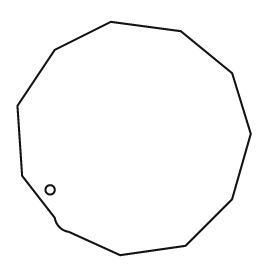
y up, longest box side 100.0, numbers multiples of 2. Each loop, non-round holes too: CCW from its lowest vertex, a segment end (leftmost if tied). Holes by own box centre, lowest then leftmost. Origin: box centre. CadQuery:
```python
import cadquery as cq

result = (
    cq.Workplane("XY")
    .moveTo(-6.0, -50.0)
    .lineTo(22.0, -46.0)
    .lineTo(42.0, -26.0)
    .lineTo(50.0, 2.0)
    .lineTo(42.0, 28.0)
    .lineTo(20.0, 46.0)
    .lineTo(-10.0, 50.0)
    .lineTo(-34.0, 38.0)
    .lineTo(-50.0, 14.0)
    .lineTo(-48.0, -16.0)
    .lineTo(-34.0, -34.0)
    .threePointArc((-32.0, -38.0), (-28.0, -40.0))
    .close()
    .moveTo(-36.0, -22.0)
    .circle(2.0)
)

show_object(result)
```